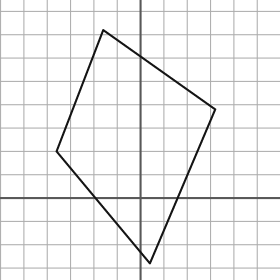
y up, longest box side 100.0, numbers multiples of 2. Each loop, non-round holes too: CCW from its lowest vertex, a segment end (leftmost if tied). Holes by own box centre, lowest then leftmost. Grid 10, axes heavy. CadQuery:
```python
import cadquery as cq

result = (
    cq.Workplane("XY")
    .moveTo(4.0, -28.0)
    .lineTo(32.0, 38.0)
    .lineTo(-16.0, 72.0)
    .lineTo(-36.0, 20.0)
    .close()
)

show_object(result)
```